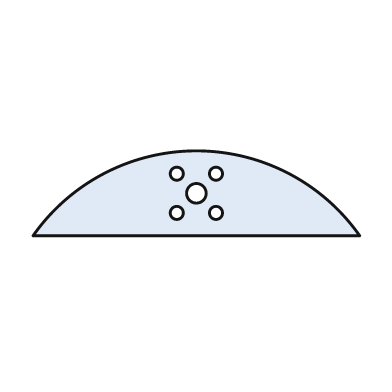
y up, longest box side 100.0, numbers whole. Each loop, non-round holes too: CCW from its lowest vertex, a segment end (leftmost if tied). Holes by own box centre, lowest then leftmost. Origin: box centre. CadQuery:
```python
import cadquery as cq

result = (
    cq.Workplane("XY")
    .moveTo(-50.0, -13.0)
    .lineTo(50.0, -13.0)
    .threePointArc((0.0, 13.0), (-50.0, -13.0))
    .close()
    .moveTo(-6.0, -6.0)
    .circle(2.0)
    .moveTo(6.0, -6.0)
    .circle(2.0)
    .moveTo(0.0, 0.0)
    .circle(3.0)
    .moveTo(-6.0, 6.0)
    .circle(2.0)
    .moveTo(6.0, 6.0)
    .circle(2.0)
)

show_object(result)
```